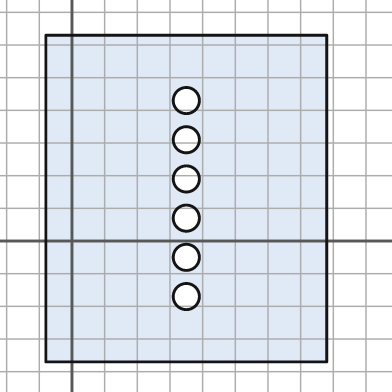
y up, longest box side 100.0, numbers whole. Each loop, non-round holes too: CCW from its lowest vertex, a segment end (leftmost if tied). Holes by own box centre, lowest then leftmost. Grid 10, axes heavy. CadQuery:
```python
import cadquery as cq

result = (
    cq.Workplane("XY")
    .moveTo(-8.0, -37.0)
    .lineTo(78.0, -37.0)
    .lineTo(78.0, 63.0)
    .lineTo(-8.0, 63.0)
    .close()
    .moveTo(35.0, -17.0)
    .circle(4.0)
    .moveTo(35.0, -5.0)
    .circle(4.0)
    .moveTo(35.0, 7.0)
    .circle(4.0)
    .moveTo(35.0, 19.0)
    .circle(4.0)
    .moveTo(35.0, 31.0)
    .circle(4.0)
    .moveTo(35.0, 43.0)
    .circle(4.0)
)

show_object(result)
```